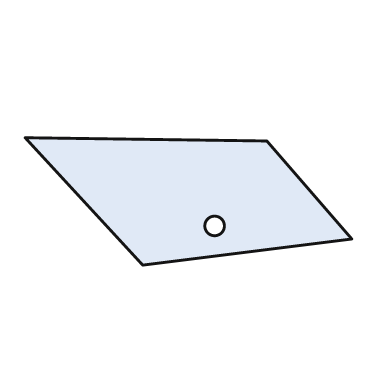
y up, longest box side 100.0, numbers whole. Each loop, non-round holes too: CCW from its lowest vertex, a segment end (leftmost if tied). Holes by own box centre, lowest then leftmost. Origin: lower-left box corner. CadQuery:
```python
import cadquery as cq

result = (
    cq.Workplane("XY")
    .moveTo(36.0, 0.0)
    .lineTo(100.0, 8.0)
    .lineTo(74.0, 38.0)
    .lineTo(0.0, 39.0)
    .close()
    .moveTo(58.0, 12.0)
    .circle(3.0)
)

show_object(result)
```